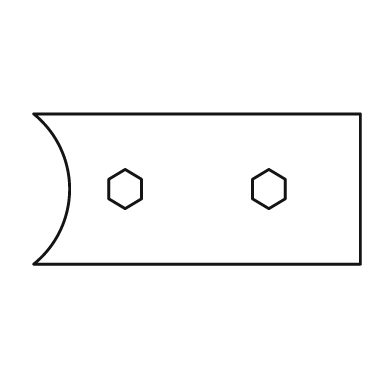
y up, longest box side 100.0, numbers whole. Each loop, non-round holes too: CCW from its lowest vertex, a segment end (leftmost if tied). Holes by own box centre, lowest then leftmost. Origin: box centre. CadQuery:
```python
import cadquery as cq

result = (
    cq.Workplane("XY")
    .moveTo(-50.0, -23.0)
    .lineTo(50.0, -23.0)
    .lineTo(50.0, 23.0)
    .lineTo(-50.0, 23.0)
    .threePointArc((-39.0, 0.0), (-50.0, -23.0))
    .close()
    .moveTo(-22.0, -6.0)
    .lineTo(-17.0, -3.0)
    .lineTo(-17.0, 3.0)
    .lineTo(-22.0, 6.0)
    .lineTo(-27.0, 3.0)
    .lineTo(-27.0, -3.0)
    .close()
    .moveTo(22.0, -6.0)
    .lineTo(27.0, -3.0)
    .lineTo(27.0, 3.0)
    .lineTo(22.0, 6.0)
    .lineTo(17.0, 3.0)
    .lineTo(17.0, -3.0)
    .close()
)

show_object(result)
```